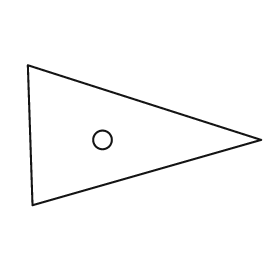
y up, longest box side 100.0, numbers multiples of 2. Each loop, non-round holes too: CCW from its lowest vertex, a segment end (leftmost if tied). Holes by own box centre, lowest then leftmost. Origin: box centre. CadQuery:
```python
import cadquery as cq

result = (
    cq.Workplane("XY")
    .moveTo(-48.0, -30.0)
    .lineTo(50.0, -2.0)
    .lineTo(-50.0, 30.0)
    .close()
    .moveTo(-18.0, -2.0)
    .circle(4.0)
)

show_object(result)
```